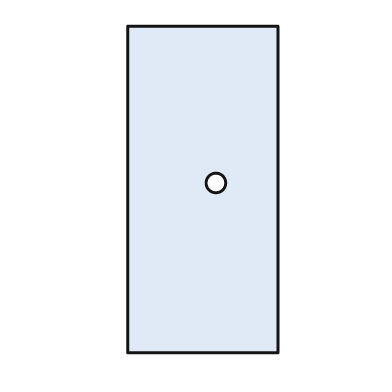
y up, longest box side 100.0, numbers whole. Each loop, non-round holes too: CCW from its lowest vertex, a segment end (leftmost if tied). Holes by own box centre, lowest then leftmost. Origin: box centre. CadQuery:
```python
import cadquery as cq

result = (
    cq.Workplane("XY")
    .moveTo(-23.0, -50.0)
    .lineTo(23.0, -50.0)
    .lineTo(23.0, 50.0)
    .lineTo(-23.0, 50.0)
    .close()
    .moveTo(4.0, 2.0)
    .circle(3.0)
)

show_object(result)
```